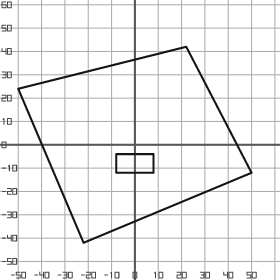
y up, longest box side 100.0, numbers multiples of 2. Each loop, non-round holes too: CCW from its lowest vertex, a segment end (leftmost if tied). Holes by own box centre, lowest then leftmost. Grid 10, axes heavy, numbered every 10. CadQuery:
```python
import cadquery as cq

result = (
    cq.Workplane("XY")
    .moveTo(-22.0, -42.0)
    .lineTo(50.0, -12.0)
    .lineTo(22.0, 42.0)
    .lineTo(-50.0, 24.0)
    .close()
    .moveTo(-8.0, -12.0)
    .lineTo(8.0, -12.0)
    .lineTo(8.0, -4.0)
    .lineTo(-8.0, -4.0)
    .close()
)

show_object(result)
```